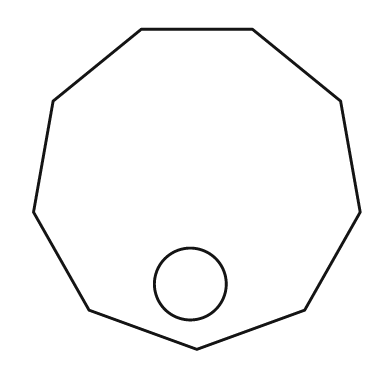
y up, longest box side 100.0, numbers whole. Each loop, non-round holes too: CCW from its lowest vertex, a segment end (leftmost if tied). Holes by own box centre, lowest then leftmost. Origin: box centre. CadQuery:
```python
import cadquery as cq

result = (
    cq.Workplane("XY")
    .moveTo(0.0, -49.0)
    .lineTo(33.0, -37.0)
    .lineTo(50.0, -7.0)
    .lineTo(44.0, 27.0)
    .lineTo(17.0, 49.0)
    .lineTo(-17.0, 49.0)
    .lineTo(-44.0, 27.0)
    .lineTo(-50.0, -7.0)
    .lineTo(-33.0, -37.0)
    .close()
    .moveTo(-2.0, -29.0)
    .circle(11.0)
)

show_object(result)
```